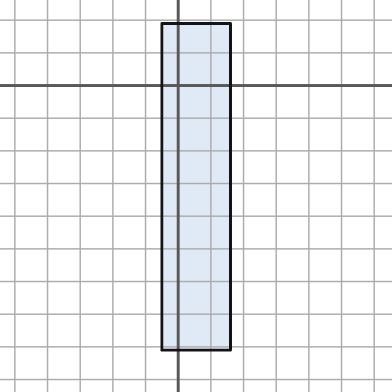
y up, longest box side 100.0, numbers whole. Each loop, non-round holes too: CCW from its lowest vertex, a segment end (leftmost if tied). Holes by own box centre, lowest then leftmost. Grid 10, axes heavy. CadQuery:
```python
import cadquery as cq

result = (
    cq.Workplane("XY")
    .moveTo(-5.0, -81.0)
    .lineTo(16.0, -81.0)
    .lineTo(16.0, 19.0)
    .lineTo(-5.0, 19.0)
    .close()
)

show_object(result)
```